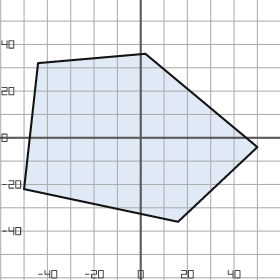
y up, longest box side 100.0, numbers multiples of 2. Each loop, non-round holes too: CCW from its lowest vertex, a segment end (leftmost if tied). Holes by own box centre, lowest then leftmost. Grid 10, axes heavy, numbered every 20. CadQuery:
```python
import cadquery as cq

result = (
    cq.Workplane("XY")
    .moveTo(16.0, -36.0)
    .lineTo(50.0, -4.0)
    .lineTo(2.0, 36.0)
    .lineTo(-44.0, 32.0)
    .lineTo(-50.0, -22.0)
    .close()
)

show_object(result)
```